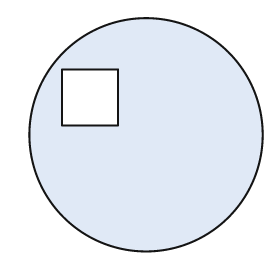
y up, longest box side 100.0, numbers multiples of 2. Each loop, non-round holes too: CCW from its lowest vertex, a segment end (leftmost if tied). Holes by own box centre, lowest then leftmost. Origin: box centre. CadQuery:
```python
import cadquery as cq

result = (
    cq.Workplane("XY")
    .moveTo(0.0, 0.0)
    .circle(50.0)
    .moveTo(-36.0, 4.0)
    .lineTo(-12.0, 4.0)
    .lineTo(-12.0, 28.0)
    .lineTo(-36.0, 28.0)
    .close()
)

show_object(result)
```